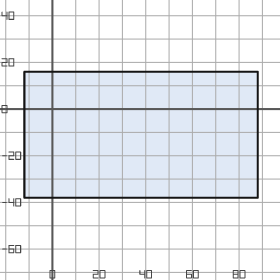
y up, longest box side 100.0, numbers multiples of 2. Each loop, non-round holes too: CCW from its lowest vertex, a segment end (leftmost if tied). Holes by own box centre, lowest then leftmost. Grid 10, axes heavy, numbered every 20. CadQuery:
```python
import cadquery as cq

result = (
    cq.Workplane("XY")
    .moveTo(-12.0, -38.0)
    .lineTo(88.0, -38.0)
    .lineTo(88.0, 16.0)
    .lineTo(-12.0, 16.0)
    .close()
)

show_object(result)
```